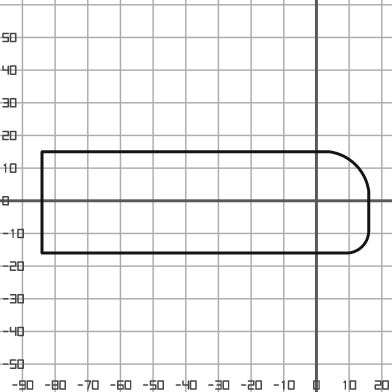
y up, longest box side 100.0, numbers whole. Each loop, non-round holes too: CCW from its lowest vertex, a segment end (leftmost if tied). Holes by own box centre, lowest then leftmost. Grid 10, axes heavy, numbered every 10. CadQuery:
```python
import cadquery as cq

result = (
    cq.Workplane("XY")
    .moveTo(-84.0, -16.0)
    .lineTo(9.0, -16.0)
    .threePointArc((14.0, -14.0), (16.0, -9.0))
    .lineTo(16.0, 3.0)
    .threePointArc((12.0, 11.0), (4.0, 15.0))
    .lineTo(-84.0, 15.0)
    .close()
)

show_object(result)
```